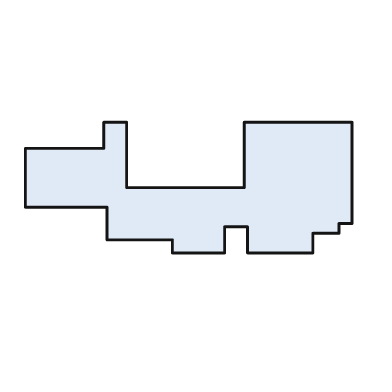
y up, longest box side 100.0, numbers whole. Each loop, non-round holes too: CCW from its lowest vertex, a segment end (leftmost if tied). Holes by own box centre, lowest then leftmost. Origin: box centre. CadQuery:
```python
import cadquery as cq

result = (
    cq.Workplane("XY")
    .moveTo(-5.0, -20.0)
    .lineTo(11.0, -20.0)
    .lineTo(11.0, -12.0)
    .lineTo(18.0, -12.0)
    .lineTo(18.0, -20.0)
    .lineTo(38.0, -20.0)
    .lineTo(38.0, -14.0)
    .lineTo(46.0, -14.0)
    .lineTo(46.0, -11.0)
    .lineTo(50.0, -11.0)
    .lineTo(50.0, 20.0)
    .lineTo(17.0, 20.0)
    .lineTo(17.0, 0.0)
    .lineTo(-19.0, 0.0)
    .lineTo(-19.0, 20.0)
    .lineTo(-26.0, 20.0)
    .lineTo(-26.0, 12.0)
    .lineTo(-50.0, 12.0)
    .lineTo(-50.0, -6.0)
    .lineTo(-25.0, -6.0)
    .lineTo(-25.0, -16.0)
    .lineTo(-5.0, -16.0)
    .close()
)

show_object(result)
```